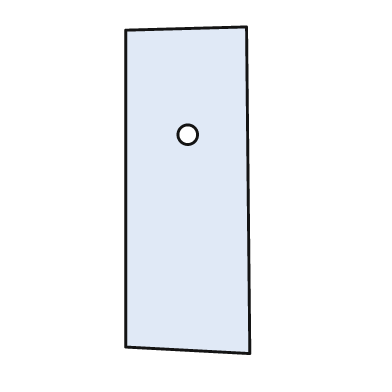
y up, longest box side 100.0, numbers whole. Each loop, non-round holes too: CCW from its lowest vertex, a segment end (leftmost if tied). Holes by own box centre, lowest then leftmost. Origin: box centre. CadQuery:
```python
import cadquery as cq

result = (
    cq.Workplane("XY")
    .moveTo(19.0, -50.0)
    .lineTo(18.0, 50.0)
    .lineTo(-19.0, 49.0)
    .lineTo(-19.0, -48.0)
    .close()
    .moveTo(0.0, 17.0)
    .circle(3.0)
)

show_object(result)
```